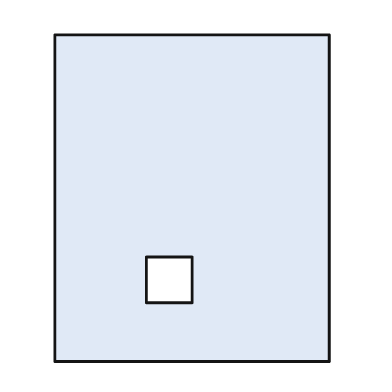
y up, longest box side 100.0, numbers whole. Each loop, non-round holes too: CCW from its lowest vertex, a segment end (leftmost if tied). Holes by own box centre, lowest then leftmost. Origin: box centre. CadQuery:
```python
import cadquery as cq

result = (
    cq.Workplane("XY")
    .moveTo(-42.0, -50.0)
    .lineTo(42.0, -50.0)
    .lineTo(42.0, 50.0)
    .lineTo(-42.0, 50.0)
    .close()
    .moveTo(-14.0, -32.0)
    .lineTo(0.0, -32.0)
    .lineTo(0.0, -18.0)
    .lineTo(-14.0, -18.0)
    .close()
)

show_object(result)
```